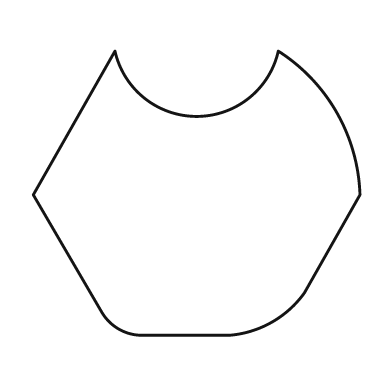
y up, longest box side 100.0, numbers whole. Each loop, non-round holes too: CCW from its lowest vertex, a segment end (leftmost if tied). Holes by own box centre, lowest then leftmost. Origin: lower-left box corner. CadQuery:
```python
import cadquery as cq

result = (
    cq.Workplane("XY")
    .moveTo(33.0, 0.0)
    .lineTo(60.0, 0.0)
    .threePointArc((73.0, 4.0), (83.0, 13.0))
    .lineTo(100.0, 43.0)
    .threePointArc((93.0, 68.0), (75.0, 87.0))
    .threePointArc((50.0, 67.0), (25.0, 87.0))
    .lineTo(0.0, 43.0)
    .lineTo(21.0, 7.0)
    .threePointArc((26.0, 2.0), (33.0, 0.0))
    .close()
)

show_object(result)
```